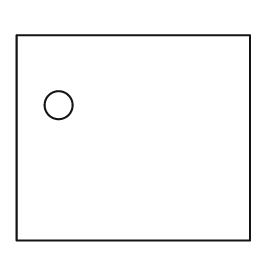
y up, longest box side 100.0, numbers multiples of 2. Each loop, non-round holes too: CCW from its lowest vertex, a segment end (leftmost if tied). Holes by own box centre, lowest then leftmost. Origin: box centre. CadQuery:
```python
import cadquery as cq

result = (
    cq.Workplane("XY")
    .moveTo(-50.0, -44.0)
    .lineTo(50.0, -44.0)
    .lineTo(50.0, 44.0)
    .lineTo(-50.0, 44.0)
    .close()
    .moveTo(-32.0, 14.0)
    .circle(6.0)
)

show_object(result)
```